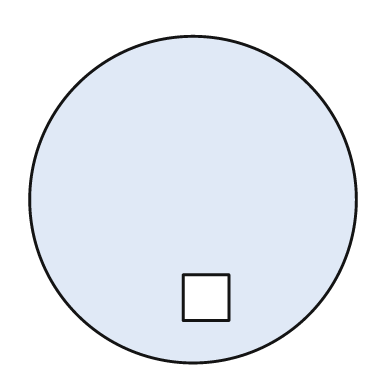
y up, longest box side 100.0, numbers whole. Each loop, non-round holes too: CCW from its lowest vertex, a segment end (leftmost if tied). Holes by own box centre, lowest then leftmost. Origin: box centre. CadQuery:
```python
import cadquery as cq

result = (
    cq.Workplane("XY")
    .moveTo(0.0, 0.0)
    .circle(50.0)
    .moveTo(-3.0, -37.0)
    .lineTo(11.0, -37.0)
    .lineTo(11.0, -23.0)
    .lineTo(-3.0, -23.0)
    .close()
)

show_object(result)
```